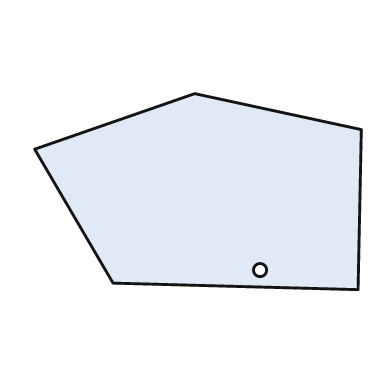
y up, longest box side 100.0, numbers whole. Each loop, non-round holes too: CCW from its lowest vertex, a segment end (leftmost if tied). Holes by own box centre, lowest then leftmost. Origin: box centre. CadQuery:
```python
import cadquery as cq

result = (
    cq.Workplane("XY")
    .moveTo(49.0, -30.0)
    .lineTo(50.0, 19.0)
    .lineTo(-1.0, 30.0)
    .lineTo(-50.0, 13.0)
    .lineTo(-26.0, -28.0)
    .close()
    .moveTo(19.0, -24.0)
    .circle(2.0)
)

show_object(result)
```